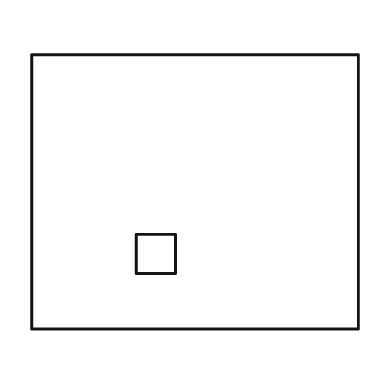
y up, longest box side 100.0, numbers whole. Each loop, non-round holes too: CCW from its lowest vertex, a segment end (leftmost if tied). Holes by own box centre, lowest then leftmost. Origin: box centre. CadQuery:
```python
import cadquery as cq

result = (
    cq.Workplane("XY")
    .moveTo(-50.0, -42.0)
    .lineTo(50.0, -42.0)
    .lineTo(50.0, 42.0)
    .lineTo(-50.0, 42.0)
    .close()
    .moveTo(-18.0, -25.0)
    .lineTo(-6.0, -25.0)
    .lineTo(-6.0, -13.0)
    .lineTo(-18.0, -13.0)
    .close()
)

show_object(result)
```